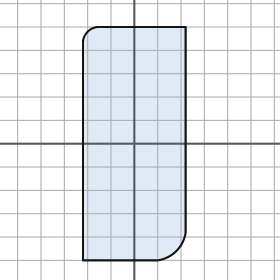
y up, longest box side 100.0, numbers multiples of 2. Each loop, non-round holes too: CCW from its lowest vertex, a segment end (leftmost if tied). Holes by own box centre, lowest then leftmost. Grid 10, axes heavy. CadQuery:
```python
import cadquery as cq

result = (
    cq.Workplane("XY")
    .moveTo(-22.0, -50.0)
    .lineTo(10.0, -50.0)
    .threePointArc((18.0, -46.0), (22.0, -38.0))
    .lineTo(22.0, 50.0)
    .lineTo(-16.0, 50.0)
    .threePointArc((-20.0, 48.0), (-22.0, 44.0))
    .close()
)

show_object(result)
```